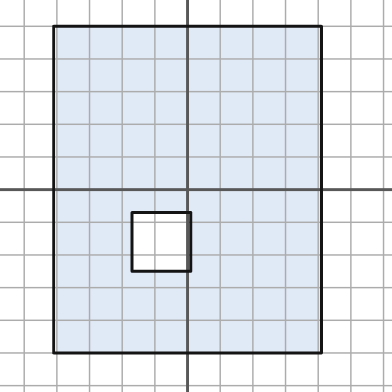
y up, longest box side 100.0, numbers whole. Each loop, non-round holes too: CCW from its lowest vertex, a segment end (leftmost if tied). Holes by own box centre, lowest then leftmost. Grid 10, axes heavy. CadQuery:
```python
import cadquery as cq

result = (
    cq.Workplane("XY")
    .moveTo(-41.0, -50.0)
    .lineTo(41.0, -50.0)
    .lineTo(41.0, 50.0)
    .lineTo(-41.0, 50.0)
    .close()
    .moveTo(-17.0, -25.0)
    .lineTo(1.0, -25.0)
    .lineTo(1.0, -7.0)
    .lineTo(-17.0, -7.0)
    .close()
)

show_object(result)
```